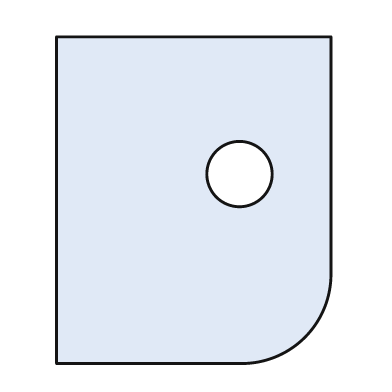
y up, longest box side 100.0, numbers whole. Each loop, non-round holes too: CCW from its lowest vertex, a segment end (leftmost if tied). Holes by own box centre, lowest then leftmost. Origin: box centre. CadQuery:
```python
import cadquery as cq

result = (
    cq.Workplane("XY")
    .moveTo(-42.0, -50.0)
    .lineTo(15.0, -50.0)
    .threePointArc((34.0, -42.0), (42.0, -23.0))
    .lineTo(42.0, 50.0)
    .lineTo(-42.0, 50.0)
    .close()
    .moveTo(14.0, 8.0)
    .circle(10.0)
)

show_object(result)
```